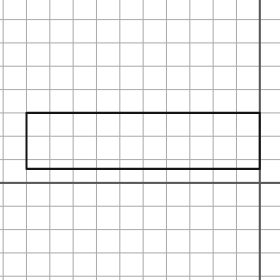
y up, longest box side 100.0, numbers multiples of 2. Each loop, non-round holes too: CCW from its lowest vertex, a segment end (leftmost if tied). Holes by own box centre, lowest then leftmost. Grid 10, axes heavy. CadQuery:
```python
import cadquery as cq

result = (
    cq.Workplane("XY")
    .moveTo(-100.0, 6.0)
    .lineTo(0.0, 6.0)
    .lineTo(0.0, 30.0)
    .lineTo(-100.0, 30.0)
    .close()
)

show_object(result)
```